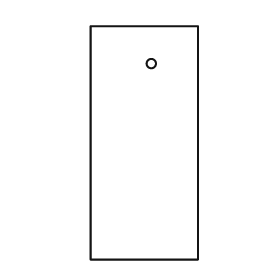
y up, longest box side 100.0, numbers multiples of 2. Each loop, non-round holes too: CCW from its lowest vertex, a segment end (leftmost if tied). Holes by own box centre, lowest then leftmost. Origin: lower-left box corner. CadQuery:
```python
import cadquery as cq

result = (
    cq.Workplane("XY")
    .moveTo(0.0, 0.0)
    .lineTo(46.0, 0.0)
    .lineTo(46.0, 100.0)
    .lineTo(0.0, 100.0)
    .close()
    .moveTo(26.0, 84.0)
    .circle(2.0)
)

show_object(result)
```